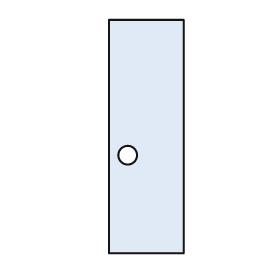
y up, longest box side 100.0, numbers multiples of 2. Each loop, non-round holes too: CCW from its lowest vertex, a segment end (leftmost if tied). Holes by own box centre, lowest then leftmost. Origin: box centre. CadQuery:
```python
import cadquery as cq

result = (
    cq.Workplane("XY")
    .moveTo(-16.0, -50.0)
    .lineTo(16.0, -50.0)
    .lineTo(16.0, 50.0)
    .lineTo(-16.0, 50.0)
    .close()
    .moveTo(-8.0, -8.0)
    .circle(4.0)
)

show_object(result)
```